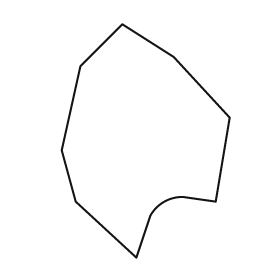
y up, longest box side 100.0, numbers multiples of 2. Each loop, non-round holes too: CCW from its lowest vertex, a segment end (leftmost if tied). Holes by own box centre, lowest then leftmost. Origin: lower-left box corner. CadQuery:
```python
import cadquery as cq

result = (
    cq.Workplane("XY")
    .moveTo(32.0, 0.0)
    .lineTo(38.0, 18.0)
    .threePointArc((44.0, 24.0), (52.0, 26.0))
    .lineTo(66.0, 24.0)
    .lineTo(72.0, 60.0)
    .lineTo(48.0, 86.0)
    .lineTo(26.0, 100.0)
    .lineTo(8.0, 82.0)
    .lineTo(0.0, 46.0)
    .lineTo(6.0, 24.0)
    .close()
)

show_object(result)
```